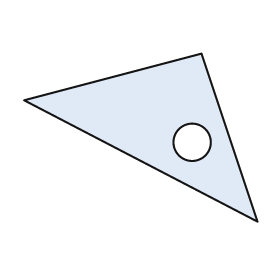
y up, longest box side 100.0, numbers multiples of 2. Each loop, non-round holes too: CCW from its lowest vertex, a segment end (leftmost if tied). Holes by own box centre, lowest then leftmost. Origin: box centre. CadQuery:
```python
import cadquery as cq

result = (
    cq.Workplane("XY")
    .moveTo(50.0, -36.0)
    .lineTo(26.0, 36.0)
    .lineTo(-50.0, 16.0)
    .close()
    .moveTo(22.0, -2.0)
    .circle(8.0)
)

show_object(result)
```